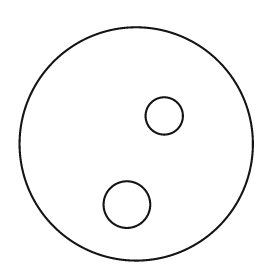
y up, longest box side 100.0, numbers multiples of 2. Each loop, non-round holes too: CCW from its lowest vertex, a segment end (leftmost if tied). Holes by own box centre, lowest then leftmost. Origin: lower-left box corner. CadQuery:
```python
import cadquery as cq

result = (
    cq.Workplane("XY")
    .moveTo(50.0, 50.0)
    .circle(50.0)
    .moveTo(46.0, 24.0)
    .circle(10.0)
    .moveTo(62.0, 62.0)
    .circle(8.0)
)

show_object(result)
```